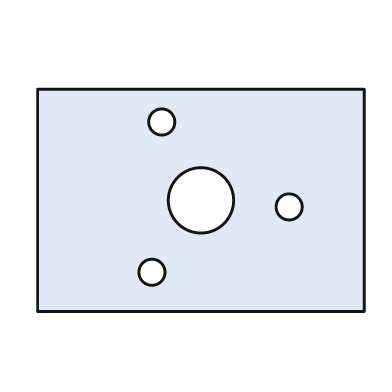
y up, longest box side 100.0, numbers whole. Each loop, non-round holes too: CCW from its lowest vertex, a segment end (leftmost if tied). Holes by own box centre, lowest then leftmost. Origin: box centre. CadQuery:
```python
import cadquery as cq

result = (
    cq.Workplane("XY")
    .moveTo(-50.0, -34.0)
    .lineTo(50.0, -34.0)
    .lineTo(50.0, 34.0)
    .lineTo(-50.0, 34.0)
    .close()
    .moveTo(-15.0, -22.0)
    .circle(4.0)
    .moveTo(27.0, -2.0)
    .circle(4.0)
    .moveTo(0.0, 0.0)
    .circle(10.0)
    .moveTo(-12.0, 24.0)
    .circle(4.0)
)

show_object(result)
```